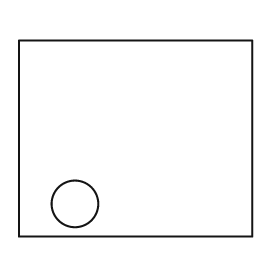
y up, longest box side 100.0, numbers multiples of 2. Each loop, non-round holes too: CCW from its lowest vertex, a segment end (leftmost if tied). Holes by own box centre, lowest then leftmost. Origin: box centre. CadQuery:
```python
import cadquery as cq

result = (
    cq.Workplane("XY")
    .moveTo(-50.0, -42.0)
    .lineTo(50.0, -42.0)
    .lineTo(50.0, 42.0)
    .lineTo(-50.0, 42.0)
    .close()
    .moveTo(-26.0, -28.0)
    .circle(10.0)
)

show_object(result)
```